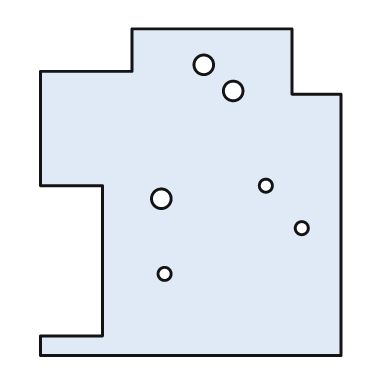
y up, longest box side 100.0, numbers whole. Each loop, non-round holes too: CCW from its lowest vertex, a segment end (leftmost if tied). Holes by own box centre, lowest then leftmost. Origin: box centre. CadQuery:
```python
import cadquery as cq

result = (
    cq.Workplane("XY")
    .moveTo(-46.0, -50.0)
    .lineTo(46.0, -50.0)
    .lineTo(46.0, 30.0)
    .lineTo(31.0, 30.0)
    .lineTo(31.0, 50.0)
    .lineTo(-18.0, 50.0)
    .lineTo(-18.0, 37.0)
    .lineTo(-46.0, 37.0)
    .lineTo(-46.0, 2.0)
    .lineTo(-27.0, 2.0)
    .lineTo(-27.0, -44.0)
    .lineTo(-46.0, -44.0)
    .close()
    .moveTo(-8.0, -25.0)
    .circle(2.0)
    .moveTo(34.0, -11.0)
    .circle(2.0)
    .moveTo(-9.0, -2.0)
    .circle(3.0)
    .moveTo(23.0, 2.0)
    .circle(2.0)
    .moveTo(13.0, 31.0)
    .circle(3.0)
    .moveTo(4.0, 39.0)
    .circle(3.0)
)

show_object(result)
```